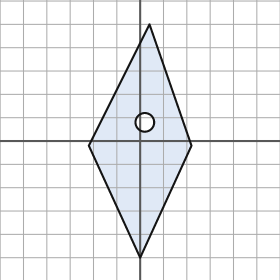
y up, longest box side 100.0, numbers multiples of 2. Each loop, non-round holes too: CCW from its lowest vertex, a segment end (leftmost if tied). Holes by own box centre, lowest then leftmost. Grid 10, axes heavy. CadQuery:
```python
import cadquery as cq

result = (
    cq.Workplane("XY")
    .moveTo(0.0, -50.0)
    .lineTo(22.0, -2.0)
    .lineTo(4.0, 50.0)
    .lineTo(-22.0, -2.0)
    .close()
    .moveTo(2.0, 8.0)
    .circle(4.0)
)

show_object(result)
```